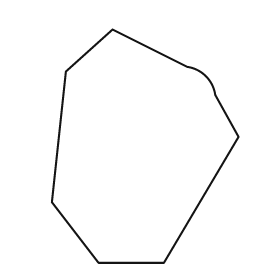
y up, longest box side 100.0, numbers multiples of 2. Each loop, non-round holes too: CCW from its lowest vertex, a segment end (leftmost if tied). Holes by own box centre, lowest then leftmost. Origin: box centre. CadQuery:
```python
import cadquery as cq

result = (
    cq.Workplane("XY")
    .moveTo(-20.0, -50.0)
    .lineTo(8.0, -50.0)
    .lineTo(40.0, 4.0)
    .lineTo(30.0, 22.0)
    .threePointArc((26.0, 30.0), (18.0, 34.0))
    .lineTo(-14.0, 50.0)
    .lineTo(-34.0, 32.0)
    .lineTo(-40.0, -24.0)
    .close()
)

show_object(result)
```